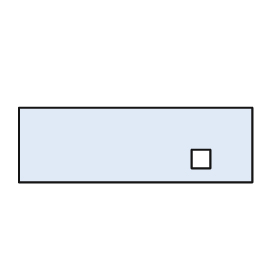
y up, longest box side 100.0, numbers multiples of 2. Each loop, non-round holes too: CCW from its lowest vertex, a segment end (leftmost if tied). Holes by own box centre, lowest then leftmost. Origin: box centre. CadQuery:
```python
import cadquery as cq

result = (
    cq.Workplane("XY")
    .moveTo(-50.0, -16.0)
    .lineTo(50.0, -16.0)
    .lineTo(50.0, 16.0)
    .lineTo(-50.0, 16.0)
    .close()
    .moveTo(24.0, -10.0)
    .lineTo(32.0, -10.0)
    .lineTo(32.0, -2.0)
    .lineTo(24.0, -2.0)
    .close()
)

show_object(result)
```